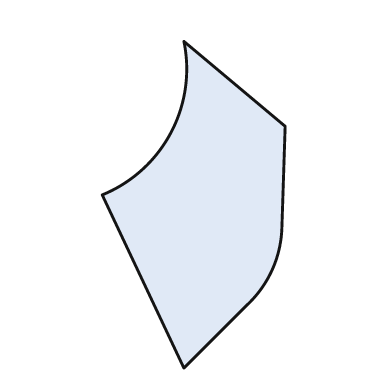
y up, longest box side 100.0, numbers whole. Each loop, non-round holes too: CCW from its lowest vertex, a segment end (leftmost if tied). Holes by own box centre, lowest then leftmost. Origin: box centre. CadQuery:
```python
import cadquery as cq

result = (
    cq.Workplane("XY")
    .moveTo(-3.0, -50.0)
    .lineTo(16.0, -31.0)
    .threePointArc((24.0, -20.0), (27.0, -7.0))
    .lineTo(28.0, 24.0)
    .lineTo(-3.0, 50.0)
    .threePointArc((-7.0, 22.0), (-28.0, 3.0))
    .close()
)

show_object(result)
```